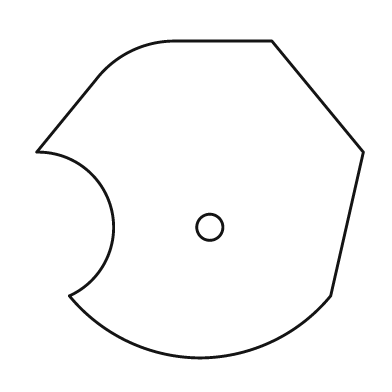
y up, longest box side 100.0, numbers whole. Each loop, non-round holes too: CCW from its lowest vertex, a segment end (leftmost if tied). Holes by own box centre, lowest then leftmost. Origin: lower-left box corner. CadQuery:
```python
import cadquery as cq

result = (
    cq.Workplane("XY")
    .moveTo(50.0, 0.0)
    .threePointArc((72.0, 5.0), (90.0, 19.0))
    .lineTo(100.0, 63.0)
    .lineTo(72.0, 97.0)
    .lineTo(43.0, 97.0)
    .threePointArc((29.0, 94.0), (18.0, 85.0))
    .lineTo(0.0, 63.0)
    .threePointArc((23.0, 45.0), (10.0, 19.0))
    .threePointArc((28.0, 5.0), (50.0, 0.0))
    .close()
    .moveTo(53.0, 40.0)
    .circle(4.0)
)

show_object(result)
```